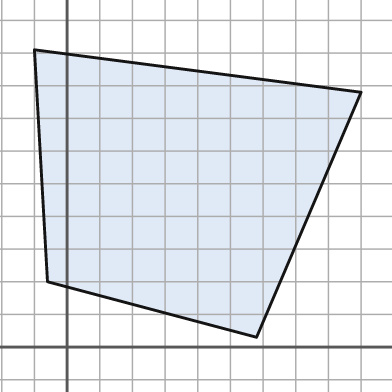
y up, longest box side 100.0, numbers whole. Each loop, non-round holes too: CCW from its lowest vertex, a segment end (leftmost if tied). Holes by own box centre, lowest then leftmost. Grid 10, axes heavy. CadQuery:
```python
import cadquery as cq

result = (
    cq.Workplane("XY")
    .moveTo(58.0, 3.0)
    .lineTo(90.0, 78.0)
    .lineTo(-10.0, 91.0)
    .lineTo(-6.0, 20.0)
    .close()
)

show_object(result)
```